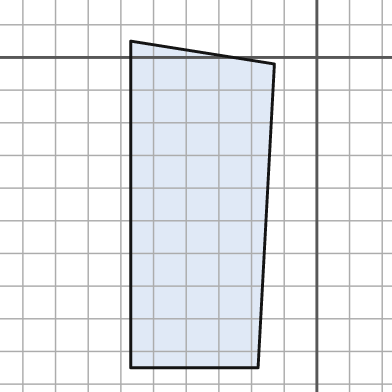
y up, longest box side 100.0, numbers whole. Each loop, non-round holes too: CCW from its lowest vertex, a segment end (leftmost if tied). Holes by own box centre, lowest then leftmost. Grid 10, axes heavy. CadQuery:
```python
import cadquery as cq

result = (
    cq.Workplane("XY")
    .moveTo(-57.0, -95.0)
    .lineTo(-18.0, -95.0)
    .lineTo(-13.0, -2.0)
    .lineTo(-57.0, 5.0)
    .close()
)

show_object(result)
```